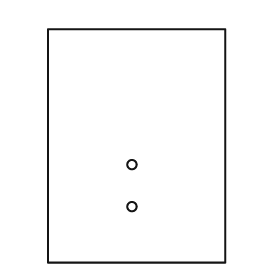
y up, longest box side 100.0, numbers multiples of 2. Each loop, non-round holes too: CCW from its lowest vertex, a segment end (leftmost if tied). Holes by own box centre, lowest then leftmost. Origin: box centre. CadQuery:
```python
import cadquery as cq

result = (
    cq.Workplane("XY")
    .moveTo(-38.0, -50.0)
    .lineTo(38.0, -50.0)
    .lineTo(38.0, 50.0)
    .lineTo(-38.0, 50.0)
    .close()
    .moveTo(-2.0, -26.0)
    .circle(2.0)
    .moveTo(-2.0, -8.0)
    .circle(2.0)
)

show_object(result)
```